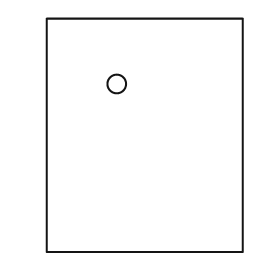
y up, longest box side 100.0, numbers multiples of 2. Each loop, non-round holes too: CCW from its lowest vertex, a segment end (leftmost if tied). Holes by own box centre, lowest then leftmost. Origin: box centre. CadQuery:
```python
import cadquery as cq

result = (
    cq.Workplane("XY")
    .moveTo(-42.0, -50.0)
    .lineTo(42.0, -50.0)
    .lineTo(42.0, 50.0)
    .lineTo(-42.0, 50.0)
    .close()
    .moveTo(-12.0, 22.0)
    .circle(4.0)
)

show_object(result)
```